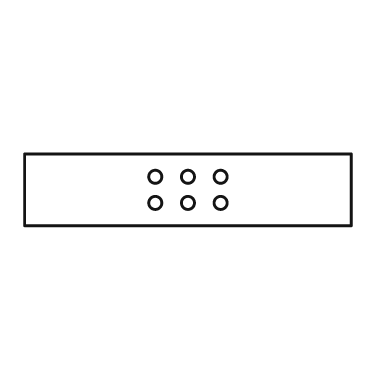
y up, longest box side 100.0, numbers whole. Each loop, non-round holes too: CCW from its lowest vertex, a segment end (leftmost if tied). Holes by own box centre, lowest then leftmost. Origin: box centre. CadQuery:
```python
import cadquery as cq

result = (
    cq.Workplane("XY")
    .moveTo(-50.0, -11.0)
    .lineTo(50.0, -11.0)
    .lineTo(50.0, 11.0)
    .lineTo(-50.0, 11.0)
    .close()
    .moveTo(-10.0, -4.0)
    .circle(2.0)
    .moveTo(0.0, -4.0)
    .circle(2.0)
    .moveTo(10.0, -4.0)
    .circle(2.0)
    .moveTo(-10.0, 4.0)
    .circle(2.0)
    .moveTo(0.0, 4.0)
    .circle(2.0)
    .moveTo(10.0, 4.0)
    .circle(2.0)
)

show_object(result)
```